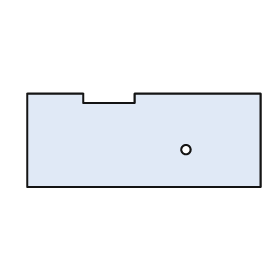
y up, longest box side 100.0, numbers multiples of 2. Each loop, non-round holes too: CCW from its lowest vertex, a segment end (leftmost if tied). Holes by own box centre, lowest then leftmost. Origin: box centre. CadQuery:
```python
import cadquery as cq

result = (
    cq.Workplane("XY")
    .moveTo(-50.0, -20.0)
    .lineTo(50.0, -20.0)
    .lineTo(50.0, 20.0)
    .lineTo(-4.0, 20.0)
    .lineTo(-4.0, 16.0)
    .lineTo(-26.0, 16.0)
    .lineTo(-26.0, 20.0)
    .lineTo(-50.0, 20.0)
    .close()
    .moveTo(18.0, -4.0)
    .circle(2.0)
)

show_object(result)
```